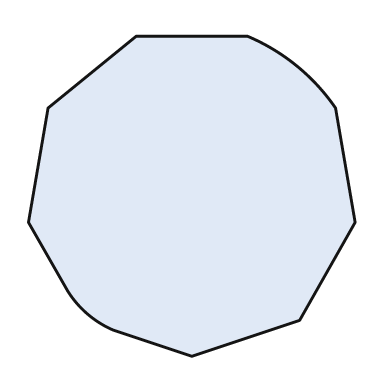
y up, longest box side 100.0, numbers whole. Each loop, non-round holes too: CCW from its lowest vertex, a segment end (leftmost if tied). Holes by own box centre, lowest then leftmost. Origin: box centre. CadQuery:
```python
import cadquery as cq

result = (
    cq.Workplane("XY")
    .moveTo(0.0, -49.0)
    .lineTo(33.0, -38.0)
    .lineTo(50.0, -8.0)
    .lineTo(44.0, 27.0)
    .threePointArc((32.0, 40.0), (17.0, 49.0))
    .lineTo(-17.0, 49.0)
    .lineTo(-44.0, 27.0)
    .lineTo(-50.0, -8.0)
    .lineTo(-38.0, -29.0)
    .threePointArc((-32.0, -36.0), (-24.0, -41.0))
    .close()
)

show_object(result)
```